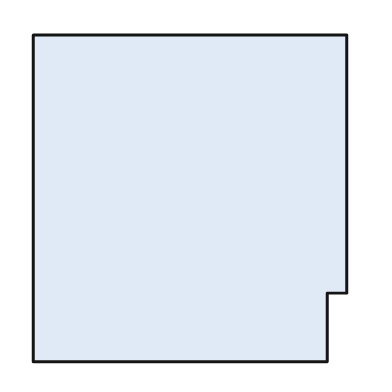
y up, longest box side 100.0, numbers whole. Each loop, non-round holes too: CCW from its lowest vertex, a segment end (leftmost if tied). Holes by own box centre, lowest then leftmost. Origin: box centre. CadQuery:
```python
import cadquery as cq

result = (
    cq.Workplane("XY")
    .moveTo(-48.0, -50.0)
    .lineTo(42.0, -50.0)
    .lineTo(42.0, -29.0)
    .lineTo(48.0, -29.0)
    .lineTo(48.0, 50.0)
    .lineTo(-48.0, 50.0)
    .close()
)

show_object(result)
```